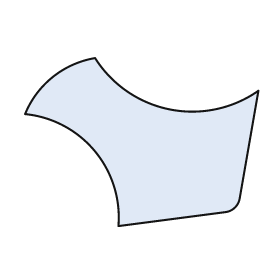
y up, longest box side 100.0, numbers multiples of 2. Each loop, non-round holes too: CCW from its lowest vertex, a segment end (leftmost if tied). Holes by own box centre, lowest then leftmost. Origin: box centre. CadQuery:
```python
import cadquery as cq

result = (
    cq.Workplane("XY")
    .moveTo(-10.0, -36.0)
    .lineTo(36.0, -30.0)
    .threePointArc((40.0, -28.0), (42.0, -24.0))
    .lineTo(50.0, 22.0)
    .threePointArc((12.0, 14.0), (-20.0, 36.0))
    .threePointArc((-38.0, 28.0), (-50.0, 12.0))
    .threePointArc((-20.0, -4.0), (-10.0, -36.0))
    .close()
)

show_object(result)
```